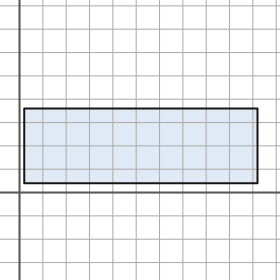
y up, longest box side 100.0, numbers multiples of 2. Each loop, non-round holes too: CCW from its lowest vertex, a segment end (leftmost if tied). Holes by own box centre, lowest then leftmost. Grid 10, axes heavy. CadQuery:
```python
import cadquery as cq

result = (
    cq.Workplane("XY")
    .moveTo(2.0, 4.0)
    .lineTo(102.0, 4.0)
    .lineTo(102.0, 36.0)
    .lineTo(2.0, 36.0)
    .close()
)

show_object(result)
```